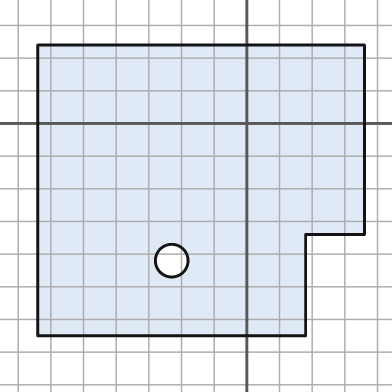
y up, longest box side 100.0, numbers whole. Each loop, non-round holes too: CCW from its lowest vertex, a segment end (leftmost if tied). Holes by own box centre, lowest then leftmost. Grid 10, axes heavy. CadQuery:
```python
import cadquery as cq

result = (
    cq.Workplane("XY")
    .moveTo(-64.0, -65.0)
    .lineTo(18.0, -65.0)
    .lineTo(18.0, -34.0)
    .lineTo(36.0, -34.0)
    .lineTo(36.0, 24.0)
    .lineTo(-64.0, 24.0)
    .close()
    .moveTo(-23.0, -42.0)
    .circle(5.0)
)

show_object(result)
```